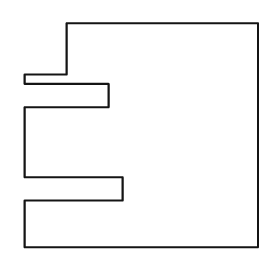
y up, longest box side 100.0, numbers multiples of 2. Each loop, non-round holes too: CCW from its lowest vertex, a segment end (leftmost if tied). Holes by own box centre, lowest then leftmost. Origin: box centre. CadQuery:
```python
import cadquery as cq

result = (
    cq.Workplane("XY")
    .moveTo(-50.0, -48.0)
    .lineTo(50.0, -48.0)
    .lineTo(50.0, 48.0)
    .lineTo(-32.0, 48.0)
    .lineTo(-32.0, 26.0)
    .lineTo(-50.0, 26.0)
    .lineTo(-50.0, 22.0)
    .lineTo(-14.0, 22.0)
    .lineTo(-14.0, 12.0)
    .lineTo(-50.0, 12.0)
    .lineTo(-50.0, -18.0)
    .lineTo(-8.0, -18.0)
    .lineTo(-8.0, -28.0)
    .lineTo(-50.0, -28.0)
    .close()
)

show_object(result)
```